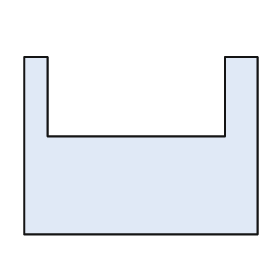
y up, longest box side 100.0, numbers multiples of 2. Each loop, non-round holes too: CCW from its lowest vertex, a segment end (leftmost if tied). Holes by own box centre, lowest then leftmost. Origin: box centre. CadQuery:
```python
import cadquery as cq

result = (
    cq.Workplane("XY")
    .moveTo(-50.0, -38.0)
    .lineTo(50.0, -38.0)
    .lineTo(50.0, 38.0)
    .lineTo(36.0, 38.0)
    .lineTo(36.0, 4.0)
    .lineTo(-40.0, 4.0)
    .lineTo(-40.0, 38.0)
    .lineTo(-50.0, 38.0)
    .close()
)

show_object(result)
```